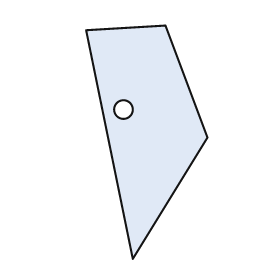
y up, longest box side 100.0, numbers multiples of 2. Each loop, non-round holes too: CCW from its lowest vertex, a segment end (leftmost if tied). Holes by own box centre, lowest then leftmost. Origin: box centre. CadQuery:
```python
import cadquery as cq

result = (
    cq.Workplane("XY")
    .moveTo(-6.0, -50.0)
    .lineTo(26.0, 2.0)
    .lineTo(8.0, 50.0)
    .lineTo(-26.0, 48.0)
    .close()
    .moveTo(-10.0, 14.0)
    .circle(4.0)
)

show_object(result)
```